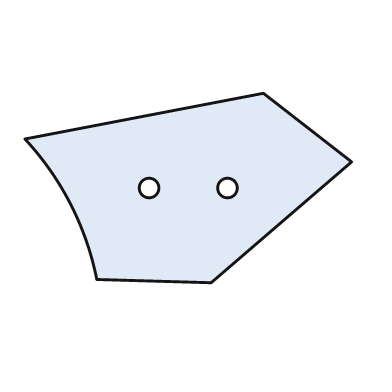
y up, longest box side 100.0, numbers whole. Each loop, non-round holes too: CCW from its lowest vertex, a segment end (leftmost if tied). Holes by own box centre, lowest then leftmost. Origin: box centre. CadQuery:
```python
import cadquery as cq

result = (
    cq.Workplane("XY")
    .moveTo(7.0, -29.0)
    .lineTo(50.0, 8.0)
    .lineTo(23.0, 29.0)
    .lineTo(-50.0, 15.0)
    .threePointArc((-36.0, -5.0), (-28.0, -28.0))
    .close()
    .moveTo(-12.0, 0.0)
    .circle(3.0)
    .moveTo(12.0, 0.0)
    .circle(3.0)
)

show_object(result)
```